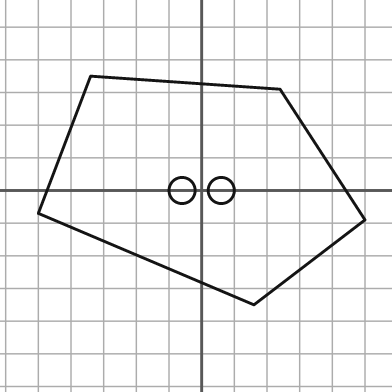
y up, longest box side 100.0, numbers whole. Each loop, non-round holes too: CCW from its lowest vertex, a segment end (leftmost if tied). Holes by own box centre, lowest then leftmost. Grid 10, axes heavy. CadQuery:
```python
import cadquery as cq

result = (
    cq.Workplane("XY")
    .moveTo(16.0, -35.0)
    .lineTo(50.0, -9.0)
    .lineTo(24.0, 31.0)
    .lineTo(-34.0, 35.0)
    .lineTo(-50.0, -7.0)
    .close()
    .moveTo(-6.0, 0.0)
    .circle(4.0)
    .moveTo(6.0, 0.0)
    .circle(4.0)
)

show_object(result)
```